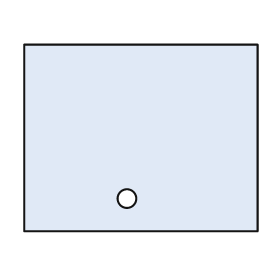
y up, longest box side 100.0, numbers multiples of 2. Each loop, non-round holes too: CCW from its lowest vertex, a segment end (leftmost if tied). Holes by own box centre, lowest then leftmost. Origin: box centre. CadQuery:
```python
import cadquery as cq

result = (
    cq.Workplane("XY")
    .moveTo(-50.0, -40.0)
    .lineTo(50.0, -40.0)
    .lineTo(50.0, 40.0)
    .lineTo(-50.0, 40.0)
    .close()
    .moveTo(-6.0, -26.0)
    .circle(4.0)
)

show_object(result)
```